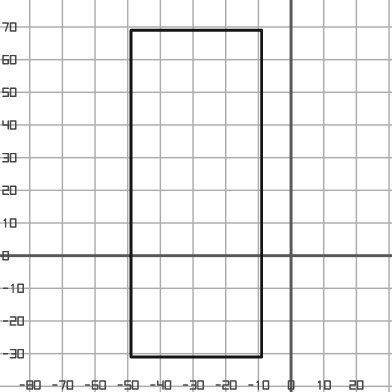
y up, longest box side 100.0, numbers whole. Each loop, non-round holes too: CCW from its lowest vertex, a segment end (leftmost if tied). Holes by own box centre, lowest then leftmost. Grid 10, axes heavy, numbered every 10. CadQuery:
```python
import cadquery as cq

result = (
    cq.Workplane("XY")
    .moveTo(-49.0, -31.0)
    .lineTo(-9.0, -31.0)
    .lineTo(-9.0, 69.0)
    .lineTo(-49.0, 69.0)
    .close()
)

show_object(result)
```